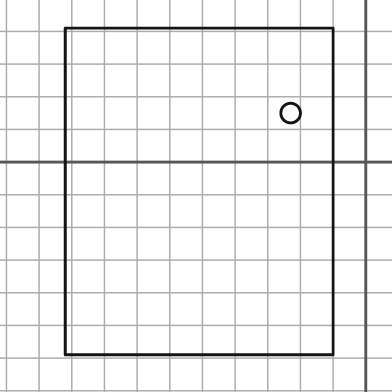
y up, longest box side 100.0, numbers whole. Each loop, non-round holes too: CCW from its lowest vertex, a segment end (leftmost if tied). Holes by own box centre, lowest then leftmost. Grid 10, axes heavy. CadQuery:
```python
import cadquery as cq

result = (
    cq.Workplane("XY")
    .moveTo(-92.0, -59.0)
    .lineTo(-10.0, -59.0)
    .lineTo(-10.0, 41.0)
    .lineTo(-92.0, 41.0)
    .close()
    .moveTo(-23.0, 15.0)
    .circle(3.0)
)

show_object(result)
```